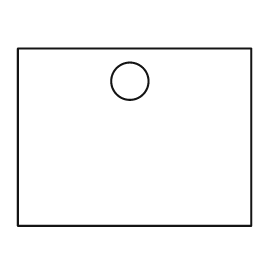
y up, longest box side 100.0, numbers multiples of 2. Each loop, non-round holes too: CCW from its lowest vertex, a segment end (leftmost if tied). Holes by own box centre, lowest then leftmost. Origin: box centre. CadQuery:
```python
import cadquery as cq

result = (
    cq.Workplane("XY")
    .moveTo(-50.0, -38.0)
    .lineTo(50.0, -38.0)
    .lineTo(50.0, 38.0)
    .lineTo(-50.0, 38.0)
    .close()
    .moveTo(-2.0, 24.0)
    .circle(8.0)
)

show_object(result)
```